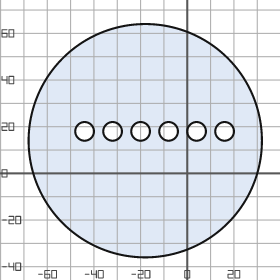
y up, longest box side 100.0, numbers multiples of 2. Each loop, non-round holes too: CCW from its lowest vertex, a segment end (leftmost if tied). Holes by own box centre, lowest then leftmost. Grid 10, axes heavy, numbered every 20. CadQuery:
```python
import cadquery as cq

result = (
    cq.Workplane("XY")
    .moveTo(-18.0, 14.0)
    .circle(50.0)
    .moveTo(-44.0, 18.0)
    .circle(4.0)
    .moveTo(-32.0, 18.0)
    .circle(4.0)
    .moveTo(-20.0, 18.0)
    .circle(4.0)
    .moveTo(-8.0, 18.0)
    .circle(4.0)
    .moveTo(4.0, 18.0)
    .circle(4.0)
    .moveTo(16.0, 18.0)
    .circle(4.0)
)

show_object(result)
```